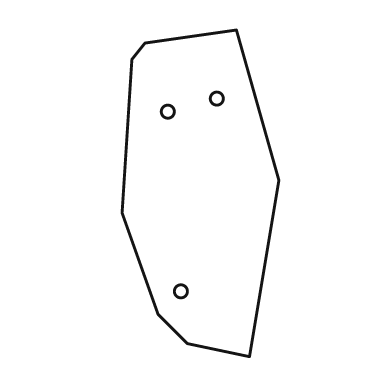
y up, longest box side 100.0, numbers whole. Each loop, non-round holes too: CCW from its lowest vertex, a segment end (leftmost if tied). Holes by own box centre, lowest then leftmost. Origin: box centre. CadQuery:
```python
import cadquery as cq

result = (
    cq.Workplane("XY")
    .moveTo(15.0, -50.0)
    .lineTo(24.0, 4.0)
    .lineTo(11.0, 50.0)
    .lineTo(-17.0, 46.0)
    .lineTo(-21.0, 41.0)
    .lineTo(-24.0, -6.0)
    .lineTo(-13.0, -37.0)
    .lineTo(-4.0, -46.0)
    .close()
    .moveTo(-6.0, -30.0)
    .circle(2.0)
    .moveTo(-10.0, 25.0)
    .circle(2.0)
    .moveTo(5.0, 29.0)
    .circle(2.0)
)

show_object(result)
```